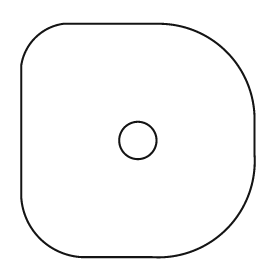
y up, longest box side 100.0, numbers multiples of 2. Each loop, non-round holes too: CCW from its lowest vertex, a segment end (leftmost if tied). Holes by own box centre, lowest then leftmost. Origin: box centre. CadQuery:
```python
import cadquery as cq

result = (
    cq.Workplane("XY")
    .moveTo(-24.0, -50.0)
    .lineTo(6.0, -50.0)
    .threePointArc((38.0, -38.0), (50.0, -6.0))
    .lineTo(50.0, 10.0)
    .threePointArc((38.0, 38.0), (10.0, 50.0))
    .lineTo(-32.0, 50.0)
    .threePointArc((-44.0, 44.0), (-50.0, 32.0))
    .lineTo(-50.0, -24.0)
    .threePointArc((-42.0, -42.0), (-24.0, -50.0))
    .close()
    .moveTo(0.0, 0.0)
    .circle(8.0)
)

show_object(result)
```